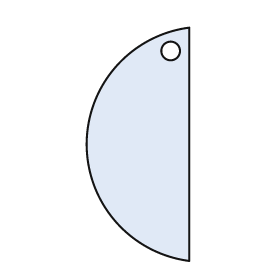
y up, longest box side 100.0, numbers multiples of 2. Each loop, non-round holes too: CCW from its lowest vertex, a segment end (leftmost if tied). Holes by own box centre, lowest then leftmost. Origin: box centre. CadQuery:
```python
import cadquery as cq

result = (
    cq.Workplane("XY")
    .moveTo(22.0, -50.0)
    .lineTo(22.0, 50.0)
    .threePointArc((-22.0, 0.0), (22.0, -50.0))
    .close()
    .moveTo(14.0, 40.0)
    .circle(4.0)
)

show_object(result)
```